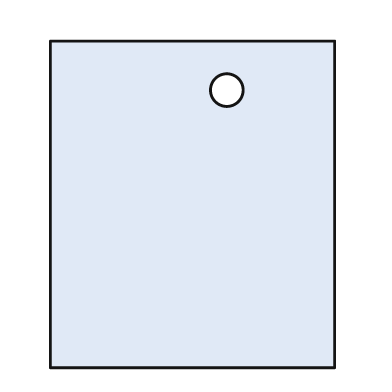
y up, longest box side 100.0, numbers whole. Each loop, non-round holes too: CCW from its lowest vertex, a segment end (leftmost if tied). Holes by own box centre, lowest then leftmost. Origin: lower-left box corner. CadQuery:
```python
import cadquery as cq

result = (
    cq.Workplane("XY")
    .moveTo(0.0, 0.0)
    .lineTo(87.0, 0.0)
    .lineTo(87.0, 100.0)
    .lineTo(0.0, 100.0)
    .close()
    .moveTo(54.0, 85.0)
    .circle(5.0)
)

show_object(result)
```